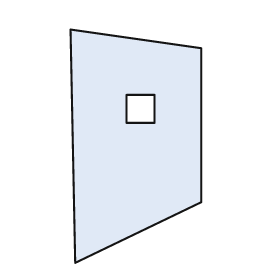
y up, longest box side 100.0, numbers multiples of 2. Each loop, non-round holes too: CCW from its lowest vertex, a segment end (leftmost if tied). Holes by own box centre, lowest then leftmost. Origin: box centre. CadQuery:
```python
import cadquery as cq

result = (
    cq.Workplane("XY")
    .moveTo(-26.0, -50.0)
    .lineTo(28.0, -24.0)
    .lineTo(28.0, 42.0)
    .lineTo(-28.0, 50.0)
    .close()
    .moveTo(-4.0, 10.0)
    .lineTo(8.0, 10.0)
    .lineTo(8.0, 22.0)
    .lineTo(-4.0, 22.0)
    .close()
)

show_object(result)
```